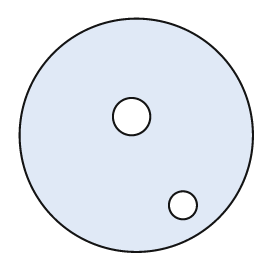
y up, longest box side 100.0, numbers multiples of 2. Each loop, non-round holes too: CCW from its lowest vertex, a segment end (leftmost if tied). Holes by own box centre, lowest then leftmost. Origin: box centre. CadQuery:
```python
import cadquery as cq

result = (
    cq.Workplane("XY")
    .moveTo(0.0, 0.0)
    .circle(50.0)
    .moveTo(20.0, -30.0)
    .circle(6.0)
    .moveTo(-2.0, 8.0)
    .circle(8.0)
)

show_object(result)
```